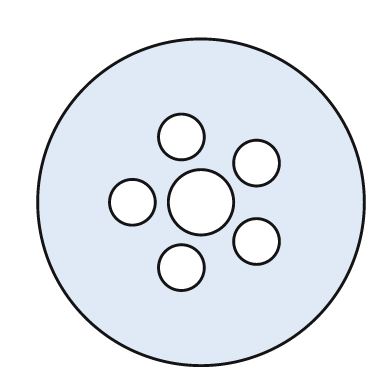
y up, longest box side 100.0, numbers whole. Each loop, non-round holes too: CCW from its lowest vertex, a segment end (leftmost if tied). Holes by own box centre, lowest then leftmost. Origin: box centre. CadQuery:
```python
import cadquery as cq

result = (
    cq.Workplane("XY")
    .moveTo(0.0, 0.0)
    .circle(50.0)
    .moveTo(-6.0, -20.0)
    .circle(7.0)
    .moveTo(17.0, -12.0)
    .circle(7.0)
    .moveTo(-21.0, 0.0)
    .circle(7.0)
    .moveTo(0.0, 0.0)
    .circle(10.0)
    .moveTo(17.0, 12.0)
    .circle(7.0)
    .moveTo(-6.0, 20.0)
    .circle(7.0)
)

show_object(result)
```